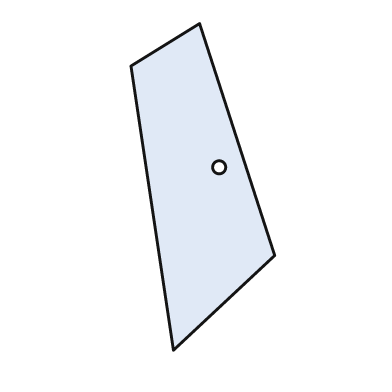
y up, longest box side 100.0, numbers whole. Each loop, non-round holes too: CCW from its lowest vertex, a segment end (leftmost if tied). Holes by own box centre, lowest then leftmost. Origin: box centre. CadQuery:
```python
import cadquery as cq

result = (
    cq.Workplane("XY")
    .moveTo(-9.0, -50.0)
    .lineTo(22.0, -21.0)
    .lineTo(-1.0, 50.0)
    .lineTo(-22.0, 37.0)
    .close()
    .moveTo(5.0, 6.0)
    .circle(2.0)
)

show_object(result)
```